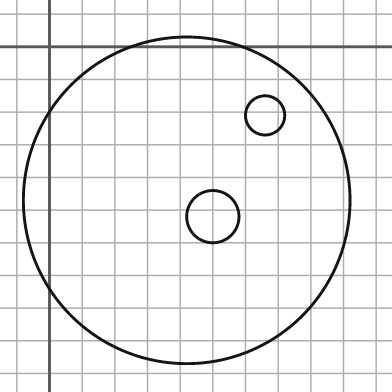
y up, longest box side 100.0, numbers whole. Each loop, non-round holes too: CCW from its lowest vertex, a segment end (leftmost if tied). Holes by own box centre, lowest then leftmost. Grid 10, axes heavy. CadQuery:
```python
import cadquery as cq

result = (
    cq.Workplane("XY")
    .moveTo(42.0, -47.0)
    .circle(50.0)
    .moveTo(50.0, -52.0)
    .circle(8.0)
    .moveTo(66.0, -21.0)
    .circle(6.0)
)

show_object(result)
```